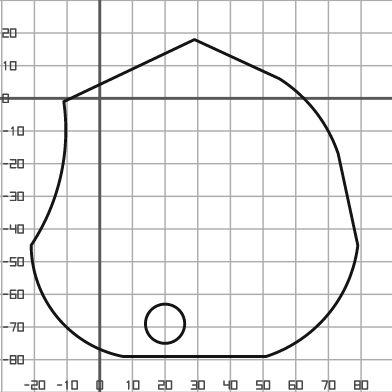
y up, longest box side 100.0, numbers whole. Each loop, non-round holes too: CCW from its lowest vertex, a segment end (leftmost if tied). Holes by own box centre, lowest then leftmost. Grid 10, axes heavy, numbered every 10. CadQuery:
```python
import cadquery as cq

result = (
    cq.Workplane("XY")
    .moveTo(7.0, -79.0)
    .lineTo(51.0, -79.0)
    .threePointArc((70.0, -66.0), (79.0, -45.0))
    .lineTo(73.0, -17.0)
    .threePointArc((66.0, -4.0), (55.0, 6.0))
    .lineTo(29.0, 18.0)
    .lineTo(-11.0, -1.0)
    .threePointArc((-12.0, -24.0), (-21.0, -45.0))
    .threePointArc((-13.0, -67.0), (7.0, -79.0))
    .close()
    .moveTo(20.0, -69.0)
    .circle(6.0)
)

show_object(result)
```